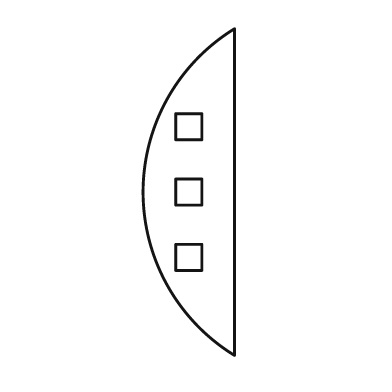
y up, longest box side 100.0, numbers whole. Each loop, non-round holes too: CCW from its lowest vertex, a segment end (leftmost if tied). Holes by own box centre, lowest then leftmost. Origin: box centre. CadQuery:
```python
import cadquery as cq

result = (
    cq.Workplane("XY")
    .moveTo(14.0, -50.0)
    .lineTo(14.0, 50.0)
    .threePointArc((-14.0, 0.0), (14.0, -50.0))
    .close()
    .moveTo(-4.0, -24.0)
    .lineTo(4.0, -24.0)
    .lineTo(4.0, -16.0)
    .lineTo(-4.0, -16.0)
    .close()
    .moveTo(-4.0, -4.0)
    .lineTo(4.0, -4.0)
    .lineTo(4.0, 4.0)
    .lineTo(-4.0, 4.0)
    .close()
    .moveTo(-4.0, 16.0)
    .lineTo(4.0, 16.0)
    .lineTo(4.0, 24.0)
    .lineTo(-4.0, 24.0)
    .close()
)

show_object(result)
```